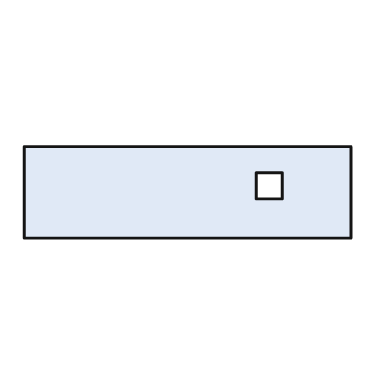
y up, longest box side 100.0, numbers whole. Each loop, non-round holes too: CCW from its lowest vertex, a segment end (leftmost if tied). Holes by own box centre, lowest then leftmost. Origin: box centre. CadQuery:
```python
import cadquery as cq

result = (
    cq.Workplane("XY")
    .moveTo(-50.0, -14.0)
    .lineTo(50.0, -14.0)
    .lineTo(50.0, 14.0)
    .lineTo(-50.0, 14.0)
    .close()
    .moveTo(21.0, -2.0)
    .lineTo(29.0, -2.0)
    .lineTo(29.0, 6.0)
    .lineTo(21.0, 6.0)
    .close()
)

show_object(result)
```